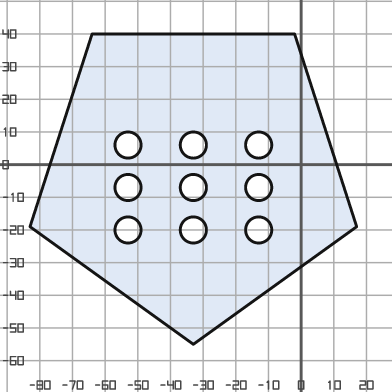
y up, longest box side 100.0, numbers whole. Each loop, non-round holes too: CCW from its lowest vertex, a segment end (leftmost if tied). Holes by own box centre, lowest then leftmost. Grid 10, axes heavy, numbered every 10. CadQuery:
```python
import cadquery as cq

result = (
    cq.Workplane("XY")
    .moveTo(-33.0, -55.0)
    .lineTo(17.0, -19.0)
    .lineTo(-2.0, 40.0)
    .lineTo(-64.0, 40.0)
    .lineTo(-83.0, -19.0)
    .close()
    .moveTo(-53.0, -20.0)
    .circle(4.0)
    .moveTo(-33.0, -20.0)
    .circle(4.0)
    .moveTo(-13.0, -20.0)
    .circle(4.0)
    .moveTo(-53.0, -7.0)
    .circle(4.0)
    .moveTo(-33.0, -7.0)
    .circle(4.0)
    .moveTo(-13.0, -7.0)
    .circle(4.0)
    .moveTo(-53.0, 6.0)
    .circle(4.0)
    .moveTo(-33.0, 6.0)
    .circle(4.0)
    .moveTo(-13.0, 6.0)
    .circle(4.0)
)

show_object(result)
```